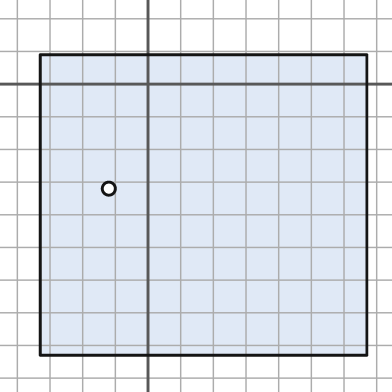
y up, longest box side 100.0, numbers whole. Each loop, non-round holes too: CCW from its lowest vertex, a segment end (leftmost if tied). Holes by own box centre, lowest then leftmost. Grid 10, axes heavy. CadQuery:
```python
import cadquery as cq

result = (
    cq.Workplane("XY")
    .moveTo(-33.0, -83.0)
    .lineTo(67.0, -83.0)
    .lineTo(67.0, 9.0)
    .lineTo(-33.0, 9.0)
    .close()
    .moveTo(-12.0, -32.0)
    .circle(2.0)
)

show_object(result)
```